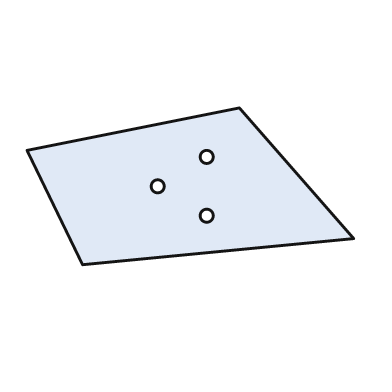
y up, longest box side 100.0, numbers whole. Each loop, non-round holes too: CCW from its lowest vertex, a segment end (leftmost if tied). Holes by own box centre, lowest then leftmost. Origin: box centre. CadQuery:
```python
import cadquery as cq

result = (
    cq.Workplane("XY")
    .moveTo(-33.0, -24.0)
    .lineTo(50.0, -16.0)
    .lineTo(15.0, 24.0)
    .lineTo(-50.0, 11.0)
    .close()
    .moveTo(5.0, -9.0)
    .circle(2.0)
    .moveTo(-10.0, 0.0)
    .circle(2.0)
    .moveTo(5.0, 9.0)
    .circle(2.0)
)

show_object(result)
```